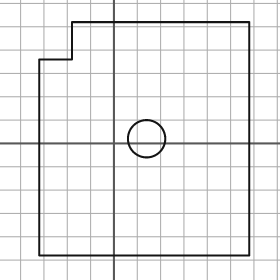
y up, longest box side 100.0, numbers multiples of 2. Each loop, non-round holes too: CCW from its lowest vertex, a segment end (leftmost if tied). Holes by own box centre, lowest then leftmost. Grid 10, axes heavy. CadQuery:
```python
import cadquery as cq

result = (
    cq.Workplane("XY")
    .moveTo(-32.0, -48.0)
    .lineTo(58.0, -48.0)
    .lineTo(58.0, 52.0)
    .lineTo(-18.0, 52.0)
    .lineTo(-18.0, 36.0)
    .lineTo(-32.0, 36.0)
    .close()
    .moveTo(14.0, 2.0)
    .circle(8.0)
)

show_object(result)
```